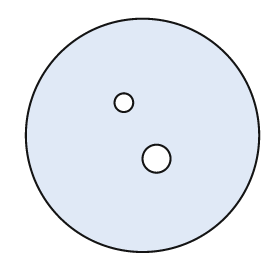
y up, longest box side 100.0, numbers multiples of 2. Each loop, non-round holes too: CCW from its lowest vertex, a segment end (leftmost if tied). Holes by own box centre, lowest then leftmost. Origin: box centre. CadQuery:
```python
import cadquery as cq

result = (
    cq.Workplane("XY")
    .moveTo(0.0, 0.0)
    .circle(50.0)
    .moveTo(6.0, -10.0)
    .circle(6.0)
    .moveTo(-8.0, 14.0)
    .circle(4.0)
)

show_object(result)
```